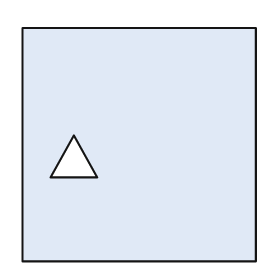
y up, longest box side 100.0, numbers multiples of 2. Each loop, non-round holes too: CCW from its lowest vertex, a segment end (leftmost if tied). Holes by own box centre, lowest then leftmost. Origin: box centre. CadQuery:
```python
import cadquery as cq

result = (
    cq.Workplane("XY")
    .moveTo(-50.0, -50.0)
    .lineTo(50.0, -50.0)
    .lineTo(50.0, 50.0)
    .lineTo(-50.0, 50.0)
    .close()
    .moveTo(-38.0, -14.0)
    .lineTo(-18.0, -14.0)
    .lineTo(-28.0, 4.0)
    .close()
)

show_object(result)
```